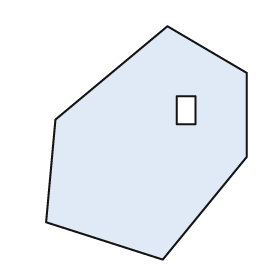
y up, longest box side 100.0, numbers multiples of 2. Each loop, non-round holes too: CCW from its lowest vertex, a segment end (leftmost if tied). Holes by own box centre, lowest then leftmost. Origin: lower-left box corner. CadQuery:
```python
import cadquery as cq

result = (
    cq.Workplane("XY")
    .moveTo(50.0, 0.0)
    .lineTo(86.0, 44.0)
    .lineTo(86.0, 80.0)
    .lineTo(52.0, 100.0)
    .lineTo(4.0, 60.0)
    .lineTo(0.0, 16.0)
    .close()
    .moveTo(56.0, 58.0)
    .lineTo(64.0, 58.0)
    .lineTo(64.0, 70.0)
    .lineTo(56.0, 70.0)
    .close()
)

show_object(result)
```